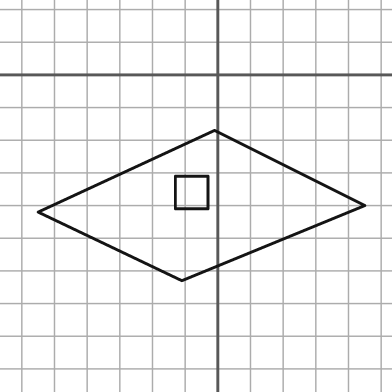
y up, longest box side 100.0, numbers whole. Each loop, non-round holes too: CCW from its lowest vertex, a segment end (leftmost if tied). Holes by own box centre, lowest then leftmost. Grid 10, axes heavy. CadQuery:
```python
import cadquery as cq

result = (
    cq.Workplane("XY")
    .moveTo(-11.0, -63.0)
    .lineTo(45.0, -40.0)
    .lineTo(-1.0, -17.0)
    .lineTo(-55.0, -42.0)
    .close()
    .moveTo(-13.0, -41.0)
    .lineTo(-3.0, -41.0)
    .lineTo(-3.0, -31.0)
    .lineTo(-13.0, -31.0)
    .close()
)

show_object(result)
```